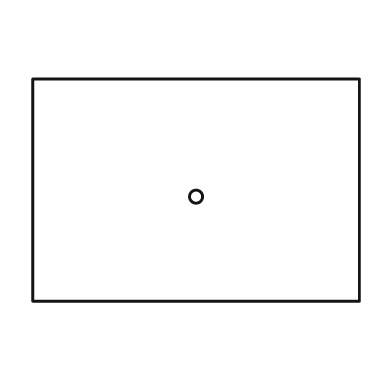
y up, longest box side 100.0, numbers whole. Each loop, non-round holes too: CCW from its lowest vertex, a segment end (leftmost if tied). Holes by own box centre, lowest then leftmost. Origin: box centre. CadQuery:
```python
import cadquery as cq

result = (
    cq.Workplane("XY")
    .moveTo(-50.0, -34.0)
    .lineTo(50.0, -34.0)
    .lineTo(50.0, 34.0)
    .lineTo(-50.0, 34.0)
    .close()
    .moveTo(0.0, -2.0)
    .circle(2.0)
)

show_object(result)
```